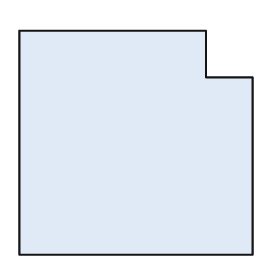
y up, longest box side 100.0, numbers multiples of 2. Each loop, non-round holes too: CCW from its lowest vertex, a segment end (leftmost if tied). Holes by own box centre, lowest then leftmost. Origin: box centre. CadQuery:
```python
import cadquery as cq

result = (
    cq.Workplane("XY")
    .moveTo(-50.0, -48.0)
    .lineTo(50.0, -48.0)
    .lineTo(50.0, 28.0)
    .lineTo(30.0, 28.0)
    .lineTo(30.0, 48.0)
    .lineTo(-50.0, 48.0)
    .close()
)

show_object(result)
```